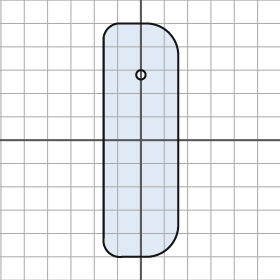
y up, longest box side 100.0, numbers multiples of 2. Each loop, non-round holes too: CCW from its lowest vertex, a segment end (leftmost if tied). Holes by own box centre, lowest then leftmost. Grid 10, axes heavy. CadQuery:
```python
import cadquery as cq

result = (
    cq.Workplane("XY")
    .moveTo(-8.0, -50.0)
    .lineTo(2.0, -50.0)
    .threePointArc((12.0, -46.0), (16.0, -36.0))
    .lineTo(16.0, 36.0)
    .threePointArc((12.0, 46.0), (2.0, 50.0))
    .lineTo(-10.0, 50.0)
    .threePointArc((-14.0, 48.0), (-16.0, 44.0))
    .lineTo(-16.0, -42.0)
    .threePointArc((-14.0, -48.0), (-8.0, -50.0))
    .close()
    .moveTo(0.0, 28.0)
    .circle(2.0)
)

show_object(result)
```